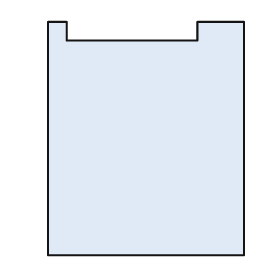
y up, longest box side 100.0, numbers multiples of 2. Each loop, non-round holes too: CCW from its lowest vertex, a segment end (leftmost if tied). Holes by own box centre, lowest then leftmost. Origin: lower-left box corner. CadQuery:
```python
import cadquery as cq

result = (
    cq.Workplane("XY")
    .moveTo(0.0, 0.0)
    .lineTo(84.0, 0.0)
    .lineTo(84.0, 100.0)
    .lineTo(64.0, 100.0)
    .lineTo(64.0, 92.0)
    .lineTo(8.0, 92.0)
    .lineTo(8.0, 100.0)
    .lineTo(0.0, 100.0)
    .close()
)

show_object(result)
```